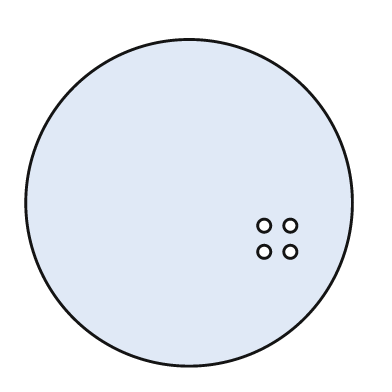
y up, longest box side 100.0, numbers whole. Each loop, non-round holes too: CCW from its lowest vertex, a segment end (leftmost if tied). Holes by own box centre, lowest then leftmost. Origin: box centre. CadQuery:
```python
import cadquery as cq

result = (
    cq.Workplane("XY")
    .moveTo(0.0, 0.0)
    .circle(50.0)
    .moveTo(23.0, -15.0)
    .circle(2.0)
    .moveTo(31.0, -15.0)
    .circle(2.0)
    .moveTo(23.0, -7.0)
    .circle(2.0)
    .moveTo(31.0, -7.0)
    .circle(2.0)
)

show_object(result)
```